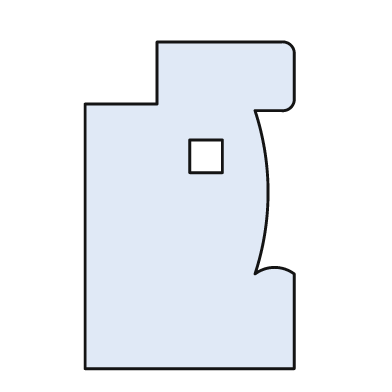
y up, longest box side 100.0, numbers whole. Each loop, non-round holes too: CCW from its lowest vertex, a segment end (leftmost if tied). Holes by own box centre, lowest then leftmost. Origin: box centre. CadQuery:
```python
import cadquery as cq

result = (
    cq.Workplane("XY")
    .moveTo(-32.0, -50.0)
    .lineTo(32.0, -50.0)
    .lineTo(32.0, -21.0)
    .threePointArc((26.0, -19.0), (20.0, -21.0))
    .threePointArc((24.0, 4.0), (20.0, 29.0))
    .lineTo(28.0, 29.0)
    .threePointArc((31.0, 30.0), (32.0, 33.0))
    .lineTo(32.0, 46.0)
    .threePointArc((31.0, 49.0), (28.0, 50.0))
    .lineTo(-10.0, 50.0)
    .lineTo(-10.0, 31.0)
    .lineTo(-32.0, 31.0)
    .close()
    .moveTo(0.0, 10.0)
    .lineTo(10.0, 10.0)
    .lineTo(10.0, 20.0)
    .lineTo(0.0, 20.0)
    .close()
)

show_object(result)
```